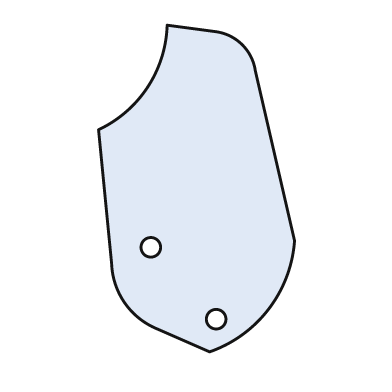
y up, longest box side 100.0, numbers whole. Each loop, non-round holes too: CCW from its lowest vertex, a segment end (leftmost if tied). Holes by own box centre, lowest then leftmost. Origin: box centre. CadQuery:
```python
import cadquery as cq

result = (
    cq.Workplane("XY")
    .moveTo(4.0, -50.0)
    .threePointArc((22.0, -37.0), (30.0, -16.0))
    .lineTo(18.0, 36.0)
    .threePointArc((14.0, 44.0), (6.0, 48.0))
    .lineTo(-9.0, 50.0)
    .threePointArc((-15.0, 31.0), (-30.0, 18.0))
    .lineTo(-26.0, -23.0)
    .threePointArc((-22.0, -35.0), (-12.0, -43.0))
    .close()
    .moveTo(6.0, -40.0)
    .circle(3.0)
    .moveTo(-14.0, -18.0)
    .circle(3.0)
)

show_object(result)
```